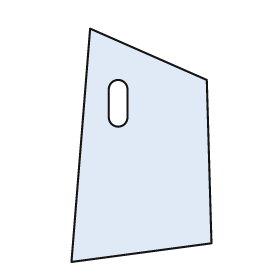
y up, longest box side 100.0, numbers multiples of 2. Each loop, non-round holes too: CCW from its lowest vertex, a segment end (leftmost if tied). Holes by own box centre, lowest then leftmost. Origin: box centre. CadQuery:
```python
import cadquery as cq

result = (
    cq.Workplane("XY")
    .moveTo(-30.0, -50.0)
    .lineTo(30.0, -42.0)
    .lineTo(28.0, 28.0)
    .lineTo(-22.0, 50.0)
    .close()
    .moveTo(-14.0, 12.0)
    .threePointArc((-10.0, 8.0), (-6.0, 12.0))
    .lineTo(-6.0, 24.0)
    .threePointArc((-10.0, 28.0), (-14.0, 24.0))
    .close()
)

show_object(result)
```